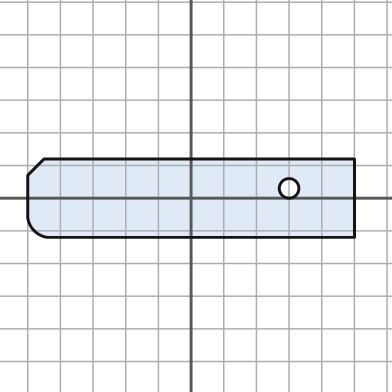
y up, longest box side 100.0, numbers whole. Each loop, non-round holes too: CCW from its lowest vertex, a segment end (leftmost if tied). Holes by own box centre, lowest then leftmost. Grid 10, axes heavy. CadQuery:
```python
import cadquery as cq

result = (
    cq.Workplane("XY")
    .moveTo(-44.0, -12.0)
    .lineTo(50.0, -12.0)
    .lineTo(50.0, 12.0)
    .lineTo(-45.0, 12.0)
    .lineTo(-50.0, 7.0)
    .lineTo(-50.0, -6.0)
    .threePointArc((-48.0, -10.0), (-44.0, -12.0))
    .close()
    .moveTo(30.0, 3.0)
    .circle(3.0)
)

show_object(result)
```